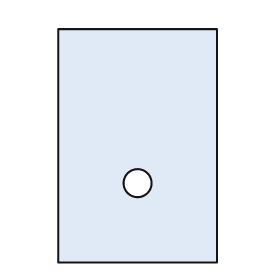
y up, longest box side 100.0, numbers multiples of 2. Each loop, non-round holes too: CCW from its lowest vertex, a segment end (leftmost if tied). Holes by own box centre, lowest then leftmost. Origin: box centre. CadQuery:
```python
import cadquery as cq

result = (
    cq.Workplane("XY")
    .moveTo(-34.0, -50.0)
    .lineTo(34.0, -50.0)
    .lineTo(34.0, 50.0)
    .lineTo(-34.0, 50.0)
    .close()
    .moveTo(0.0, -16.0)
    .circle(6.0)
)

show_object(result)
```